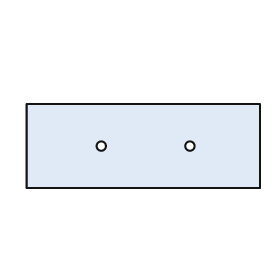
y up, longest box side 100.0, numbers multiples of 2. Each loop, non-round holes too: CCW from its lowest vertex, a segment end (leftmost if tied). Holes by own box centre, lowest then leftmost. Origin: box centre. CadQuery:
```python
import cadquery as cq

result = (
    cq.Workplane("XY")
    .moveTo(-50.0, -18.0)
    .lineTo(50.0, -18.0)
    .lineTo(50.0, 18.0)
    .lineTo(-50.0, 18.0)
    .close()
    .moveTo(-18.0, 0.0)
    .circle(2.0)
    .moveTo(20.0, 0.0)
    .circle(2.0)
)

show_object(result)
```